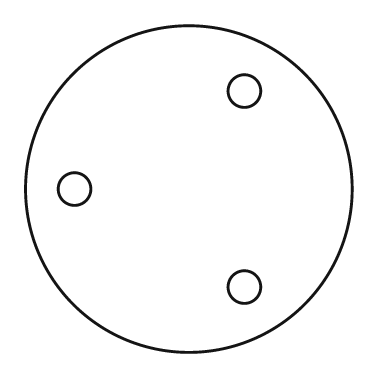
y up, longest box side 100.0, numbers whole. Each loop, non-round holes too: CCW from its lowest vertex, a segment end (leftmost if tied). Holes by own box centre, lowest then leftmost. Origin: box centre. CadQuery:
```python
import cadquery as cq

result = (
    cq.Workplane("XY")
    .moveTo(0.0, 0.0)
    .circle(50.0)
    .moveTo(17.0, -30.0)
    .circle(5.0)
    .moveTo(-35.0, 0.0)
    .circle(5.0)
    .moveTo(17.0, 30.0)
    .circle(5.0)
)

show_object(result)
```